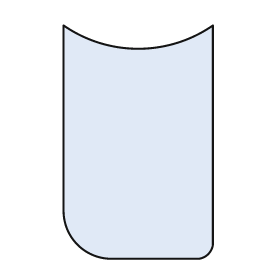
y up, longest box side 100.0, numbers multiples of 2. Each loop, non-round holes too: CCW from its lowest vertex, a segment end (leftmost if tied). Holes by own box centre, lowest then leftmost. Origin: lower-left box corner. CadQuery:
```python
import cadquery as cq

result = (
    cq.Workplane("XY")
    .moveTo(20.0, 0.0)
    .lineTo(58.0, 0.0)
    .threePointArc((62.0, 2.0), (64.0, 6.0))
    .lineTo(64.0, 100.0)
    .threePointArc((32.0, 90.0), (0.0, 100.0))
    .lineTo(0.0, 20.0)
    .threePointArc((6.0, 6.0), (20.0, 0.0))
    .close()
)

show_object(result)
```